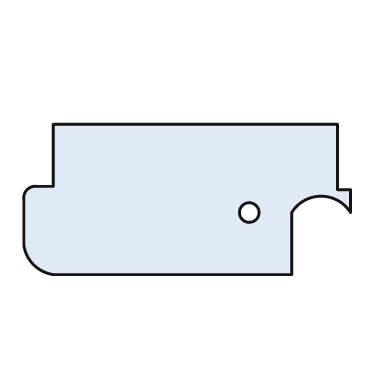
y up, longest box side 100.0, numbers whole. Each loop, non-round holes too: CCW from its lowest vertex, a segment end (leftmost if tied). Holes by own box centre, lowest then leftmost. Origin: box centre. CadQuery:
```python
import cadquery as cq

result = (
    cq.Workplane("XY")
    .moveTo(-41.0, -23.0)
    .lineTo(32.0, -23.0)
    .lineTo(32.0, -4.0)
    .threePointArc((41.0, 1.0), (50.0, -4.0))
    .lineTo(50.0, 3.0)
    .lineTo(46.0, 3.0)
    .lineTo(46.0, 23.0)
    .lineTo(-41.0, 23.0)
    .lineTo(-41.0, 4.0)
    .lineTo(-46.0, 4.0)
    .threePointArc((-49.0, 3.0), (-50.0, 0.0))
    .lineTo(-50.0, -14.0)
    .threePointArc((-47.0, -20.0), (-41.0, -23.0))
    .close()
    .moveTo(19.0, -4.0)
    .circle(3.0)
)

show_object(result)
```